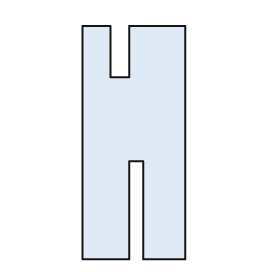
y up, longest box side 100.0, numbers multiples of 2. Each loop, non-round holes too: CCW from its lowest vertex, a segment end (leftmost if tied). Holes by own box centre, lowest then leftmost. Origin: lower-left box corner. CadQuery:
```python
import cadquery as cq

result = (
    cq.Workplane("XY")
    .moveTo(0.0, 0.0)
    .lineTo(20.0, 0.0)
    .lineTo(20.0, 42.0)
    .lineTo(26.0, 42.0)
    .lineTo(26.0, 0.0)
    .lineTo(44.0, 0.0)
    .lineTo(44.0, 100.0)
    .lineTo(20.0, 100.0)
    .lineTo(20.0, 78.0)
    .lineTo(12.0, 78.0)
    .lineTo(12.0, 100.0)
    .lineTo(0.0, 100.0)
    .close()
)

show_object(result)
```